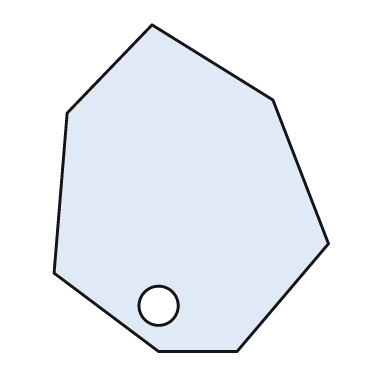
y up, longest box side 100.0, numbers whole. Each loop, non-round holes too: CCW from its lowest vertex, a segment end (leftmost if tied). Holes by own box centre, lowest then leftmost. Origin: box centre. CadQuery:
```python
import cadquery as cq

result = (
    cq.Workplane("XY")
    .moveTo(-10.0, -50.0)
    .lineTo(14.0, -50.0)
    .lineTo(42.0, -17.0)
    .lineTo(25.0, 27.0)
    .lineTo(-12.0, 50.0)
    .lineTo(-38.0, 23.0)
    .lineTo(-42.0, -26.0)
    .close()
    .moveTo(-10.0, -36.0)
    .circle(6.0)
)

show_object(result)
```